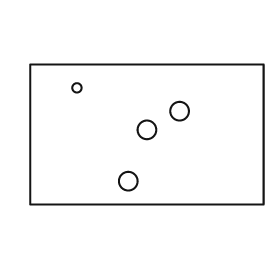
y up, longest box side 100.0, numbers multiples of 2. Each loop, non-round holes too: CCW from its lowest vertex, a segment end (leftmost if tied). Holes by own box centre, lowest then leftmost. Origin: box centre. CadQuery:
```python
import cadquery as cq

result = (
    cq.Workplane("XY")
    .moveTo(-50.0, -30.0)
    .lineTo(50.0, -30.0)
    .lineTo(50.0, 30.0)
    .lineTo(-50.0, 30.0)
    .close()
    .moveTo(-8.0, -20.0)
    .circle(4.0)
    .moveTo(0.0, 2.0)
    .circle(4.0)
    .moveTo(14.0, 10.0)
    .circle(4.0)
    .moveTo(-30.0, 20.0)
    .circle(2.0)
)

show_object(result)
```